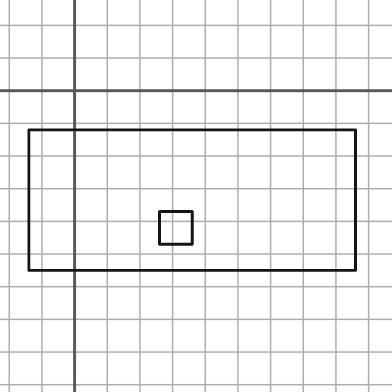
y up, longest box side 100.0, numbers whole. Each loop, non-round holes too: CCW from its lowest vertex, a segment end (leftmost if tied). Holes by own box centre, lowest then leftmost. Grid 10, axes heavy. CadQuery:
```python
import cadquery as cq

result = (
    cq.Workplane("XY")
    .moveTo(-14.0, -55.0)
    .lineTo(86.0, -55.0)
    .lineTo(86.0, -12.0)
    .lineTo(-14.0, -12.0)
    .close()
    .moveTo(26.0, -47.0)
    .lineTo(36.0, -47.0)
    .lineTo(36.0, -37.0)
    .lineTo(26.0, -37.0)
    .close()
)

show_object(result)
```